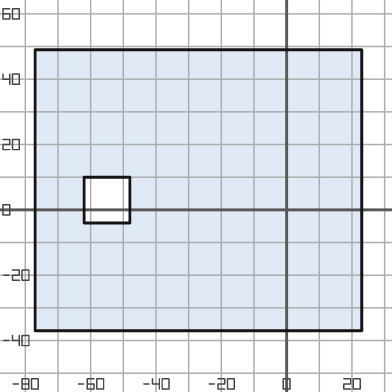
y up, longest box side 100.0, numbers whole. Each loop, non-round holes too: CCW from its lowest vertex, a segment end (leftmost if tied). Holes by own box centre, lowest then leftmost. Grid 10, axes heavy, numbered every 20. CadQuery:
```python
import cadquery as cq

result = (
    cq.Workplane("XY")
    .moveTo(-77.0, -37.0)
    .lineTo(23.0, -37.0)
    .lineTo(23.0, 49.0)
    .lineTo(-77.0, 49.0)
    .close()
    .moveTo(-62.0, -4.0)
    .lineTo(-48.0, -4.0)
    .lineTo(-48.0, 10.0)
    .lineTo(-62.0, 10.0)
    .close()
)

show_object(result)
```